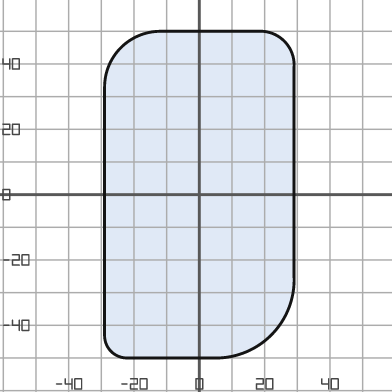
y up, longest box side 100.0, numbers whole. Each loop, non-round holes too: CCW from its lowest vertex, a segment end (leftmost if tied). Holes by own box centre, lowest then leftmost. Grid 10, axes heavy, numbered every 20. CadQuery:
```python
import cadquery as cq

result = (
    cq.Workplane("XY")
    .moveTo(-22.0, -50.0)
    .lineTo(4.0, -50.0)
    .threePointArc((22.0, -43.0), (29.0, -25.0))
    .lineTo(29.0, 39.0)
    .threePointArc((26.0, 47.0), (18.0, 50.0))
    .lineTo(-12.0, 50.0)
    .threePointArc((-24.0, 45.0), (-29.0, 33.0))
    .lineTo(-29.0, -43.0)
    .threePointArc((-27.0, -48.0), (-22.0, -50.0))
    .close()
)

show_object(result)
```